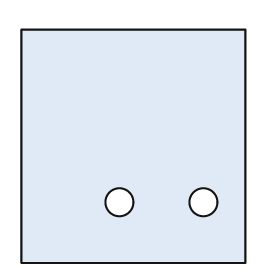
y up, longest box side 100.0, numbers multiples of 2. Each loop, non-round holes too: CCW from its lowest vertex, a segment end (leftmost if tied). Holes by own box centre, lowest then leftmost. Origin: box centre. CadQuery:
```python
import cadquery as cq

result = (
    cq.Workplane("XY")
    .moveTo(-48.0, -50.0)
    .lineTo(48.0, -50.0)
    .lineTo(48.0, 50.0)
    .lineTo(-48.0, 50.0)
    .close()
    .moveTo(-6.0, -24.0)
    .circle(6.0)
    .moveTo(30.0, -24.0)
    .circle(6.0)
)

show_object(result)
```